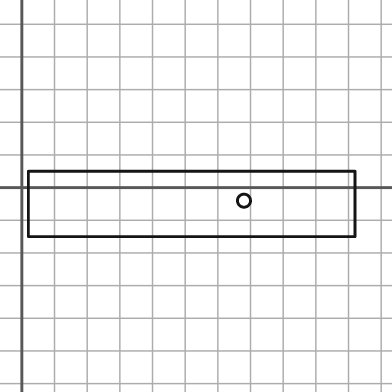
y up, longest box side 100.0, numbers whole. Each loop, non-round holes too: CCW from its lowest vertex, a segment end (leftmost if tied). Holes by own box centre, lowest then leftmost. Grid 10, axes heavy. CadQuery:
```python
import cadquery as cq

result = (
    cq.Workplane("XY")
    .moveTo(2.0, -15.0)
    .lineTo(102.0, -15.0)
    .lineTo(102.0, 5.0)
    .lineTo(2.0, 5.0)
    .close()
    .moveTo(68.0, -4.0)
    .circle(2.0)
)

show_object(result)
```